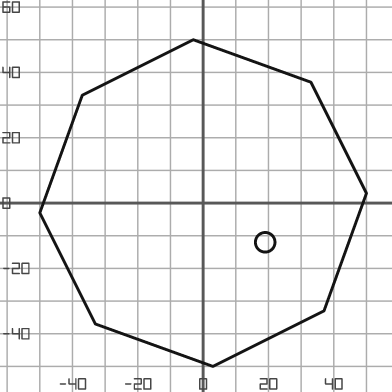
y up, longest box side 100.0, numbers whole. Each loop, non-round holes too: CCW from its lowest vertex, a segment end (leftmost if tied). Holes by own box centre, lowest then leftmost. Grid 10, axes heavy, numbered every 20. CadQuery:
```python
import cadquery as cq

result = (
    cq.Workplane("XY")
    .moveTo(3.0, -50.0)
    .lineTo(37.0, -33.0)
    .lineTo(50.0, 3.0)
    .lineTo(33.0, 37.0)
    .lineTo(-3.0, 50.0)
    .lineTo(-37.0, 33.0)
    .lineTo(-50.0, -3.0)
    .lineTo(-33.0, -37.0)
    .close()
    .moveTo(19.0, -12.0)
    .circle(3.0)
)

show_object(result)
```